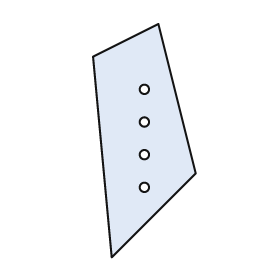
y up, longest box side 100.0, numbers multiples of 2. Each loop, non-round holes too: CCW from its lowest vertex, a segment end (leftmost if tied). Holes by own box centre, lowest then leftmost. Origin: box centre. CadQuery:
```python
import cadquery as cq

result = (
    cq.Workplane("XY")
    .moveTo(-14.0, -50.0)
    .lineTo(22.0, -14.0)
    .lineTo(6.0, 50.0)
    .lineTo(-22.0, 36.0)
    .close()
    .moveTo(0.0, -20.0)
    .circle(2.0)
    .moveTo(0.0, -6.0)
    .circle(2.0)
    .moveTo(0.0, 8.0)
    .circle(2.0)
    .moveTo(0.0, 22.0)
    .circle(2.0)
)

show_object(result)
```